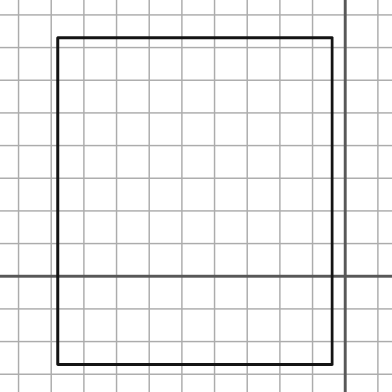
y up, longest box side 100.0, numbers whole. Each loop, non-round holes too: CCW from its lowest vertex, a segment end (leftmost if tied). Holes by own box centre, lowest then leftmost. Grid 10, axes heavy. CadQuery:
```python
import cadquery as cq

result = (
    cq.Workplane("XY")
    .moveTo(-88.0, -27.0)
    .lineTo(-4.0, -27.0)
    .lineTo(-4.0, 73.0)
    .lineTo(-88.0, 73.0)
    .close()
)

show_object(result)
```